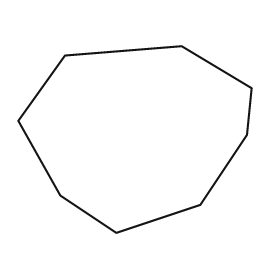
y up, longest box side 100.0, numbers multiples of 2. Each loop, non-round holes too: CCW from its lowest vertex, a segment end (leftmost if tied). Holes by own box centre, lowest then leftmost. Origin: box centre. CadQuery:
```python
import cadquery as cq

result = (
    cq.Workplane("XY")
    .moveTo(-8.0, -40.0)
    .lineTo(28.0, -28.0)
    .lineTo(48.0, 2.0)
    .lineTo(50.0, 22.0)
    .lineTo(20.0, 40.0)
    .lineTo(-30.0, 36.0)
    .lineTo(-50.0, 8.0)
    .lineTo(-32.0, -24.0)
    .close()
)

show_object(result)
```